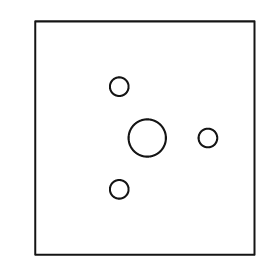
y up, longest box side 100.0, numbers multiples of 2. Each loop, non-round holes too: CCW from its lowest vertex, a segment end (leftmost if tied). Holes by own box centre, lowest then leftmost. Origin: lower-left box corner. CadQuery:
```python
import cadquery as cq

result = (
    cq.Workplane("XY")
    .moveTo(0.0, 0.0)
    .lineTo(94.0, 0.0)
    .lineTo(94.0, 100.0)
    .lineTo(0.0, 100.0)
    .close()
    .moveTo(36.0, 28.0)
    .circle(4.0)
    .moveTo(48.0, 50.0)
    .circle(8.0)
    .moveTo(74.0, 50.0)
    .circle(4.0)
    .moveTo(36.0, 72.0)
    .circle(4.0)
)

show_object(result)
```